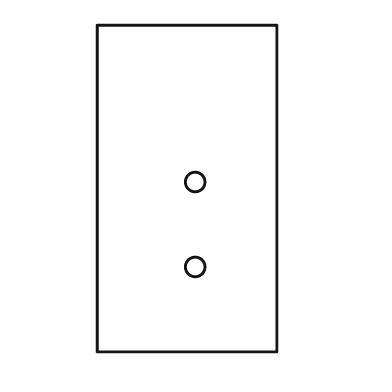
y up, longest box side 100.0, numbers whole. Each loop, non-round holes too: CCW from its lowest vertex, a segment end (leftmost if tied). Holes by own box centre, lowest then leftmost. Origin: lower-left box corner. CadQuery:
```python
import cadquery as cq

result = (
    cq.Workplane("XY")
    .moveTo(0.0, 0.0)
    .lineTo(55.0, 0.0)
    .lineTo(55.0, 100.0)
    .lineTo(0.0, 100.0)
    .close()
    .moveTo(30.0, 26.0)
    .circle(3.0)
    .moveTo(30.0, 52.0)
    .circle(3.0)
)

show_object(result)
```